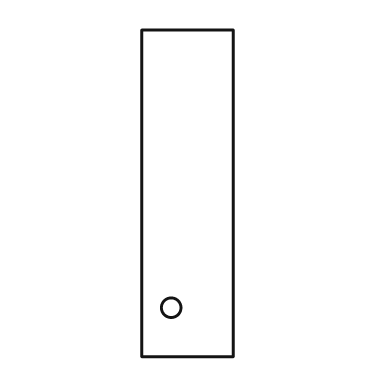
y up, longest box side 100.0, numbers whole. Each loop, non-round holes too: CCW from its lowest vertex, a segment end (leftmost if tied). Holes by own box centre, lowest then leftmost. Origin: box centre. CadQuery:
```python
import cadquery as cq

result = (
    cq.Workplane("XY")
    .moveTo(-14.0, -50.0)
    .lineTo(14.0, -50.0)
    .lineTo(14.0, 50.0)
    .lineTo(-14.0, 50.0)
    .close()
    .moveTo(-5.0, -35.0)
    .circle(3.0)
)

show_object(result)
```